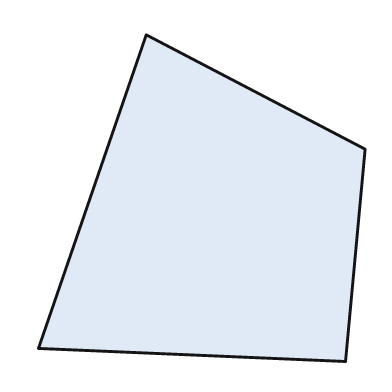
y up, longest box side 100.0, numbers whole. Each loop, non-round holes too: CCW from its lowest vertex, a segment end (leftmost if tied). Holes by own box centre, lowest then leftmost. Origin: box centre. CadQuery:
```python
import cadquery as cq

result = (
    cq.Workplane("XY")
    .moveTo(44.0, -50.0)
    .lineTo(50.0, 15.0)
    .lineTo(-17.0, 50.0)
    .lineTo(-50.0, -46.0)
    .close()
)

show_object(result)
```